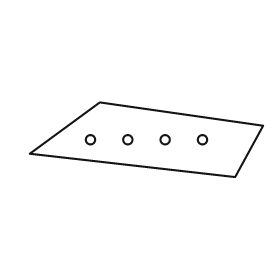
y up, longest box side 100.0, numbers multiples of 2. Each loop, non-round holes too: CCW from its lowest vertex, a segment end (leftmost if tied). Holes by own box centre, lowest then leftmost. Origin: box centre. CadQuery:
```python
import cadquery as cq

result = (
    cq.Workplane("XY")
    .moveTo(38.0, -16.0)
    .lineTo(50.0, 6.0)
    .lineTo(-20.0, 16.0)
    .lineTo(-50.0, -6.0)
    .close()
    .moveTo(-24.0, 0.0)
    .circle(2.0)
    .moveTo(-8.0, 0.0)
    .circle(2.0)
    .moveTo(8.0, 0.0)
    .circle(2.0)
    .moveTo(24.0, 0.0)
    .circle(2.0)
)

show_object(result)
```